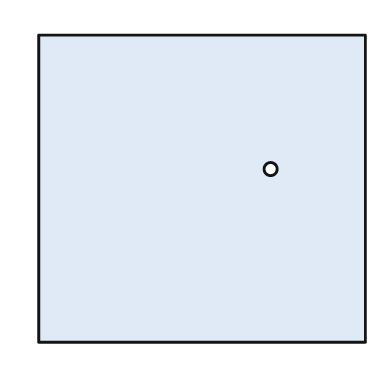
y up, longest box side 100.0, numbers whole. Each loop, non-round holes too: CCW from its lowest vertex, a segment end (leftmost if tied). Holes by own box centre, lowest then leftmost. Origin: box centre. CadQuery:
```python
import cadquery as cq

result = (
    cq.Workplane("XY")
    .moveTo(-50.0, -47.0)
    .lineTo(50.0, -47.0)
    .lineTo(50.0, 47.0)
    .lineTo(-50.0, 47.0)
    .close()
    .moveTo(21.0, 6.0)
    .circle(2.0)
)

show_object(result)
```